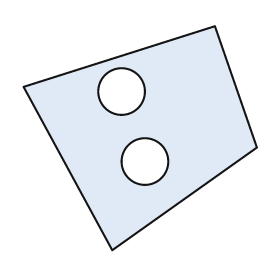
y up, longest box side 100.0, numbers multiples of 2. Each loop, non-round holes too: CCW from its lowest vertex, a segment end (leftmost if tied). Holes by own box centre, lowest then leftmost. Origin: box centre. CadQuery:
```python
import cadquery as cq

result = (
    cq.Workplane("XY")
    .moveTo(-12.0, -48.0)
    .lineTo(50.0, -4.0)
    .lineTo(32.0, 48.0)
    .lineTo(-50.0, 22.0)
    .close()
    .moveTo(2.0, -10.0)
    .circle(10.0)
    .moveTo(-8.0, 20.0)
    .circle(10.0)
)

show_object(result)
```